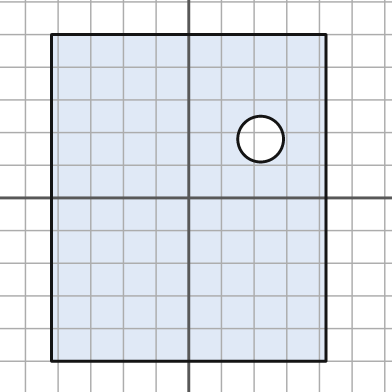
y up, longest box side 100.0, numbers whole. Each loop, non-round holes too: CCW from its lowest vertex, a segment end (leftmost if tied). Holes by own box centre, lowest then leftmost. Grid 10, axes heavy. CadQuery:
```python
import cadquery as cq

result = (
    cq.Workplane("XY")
    .moveTo(-42.0, -50.0)
    .lineTo(42.0, -50.0)
    .lineTo(42.0, 50.0)
    .lineTo(-42.0, 50.0)
    .close()
    .moveTo(22.0, 18.0)
    .circle(7.0)
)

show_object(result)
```